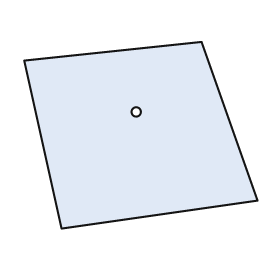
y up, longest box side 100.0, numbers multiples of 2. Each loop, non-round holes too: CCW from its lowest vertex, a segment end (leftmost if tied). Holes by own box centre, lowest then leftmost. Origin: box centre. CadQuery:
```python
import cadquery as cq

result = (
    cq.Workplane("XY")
    .moveTo(-34.0, -40.0)
    .lineTo(50.0, -28.0)
    .lineTo(26.0, 40.0)
    .lineTo(-50.0, 32.0)
    .close()
    .moveTo(-2.0, 10.0)
    .circle(2.0)
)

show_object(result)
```